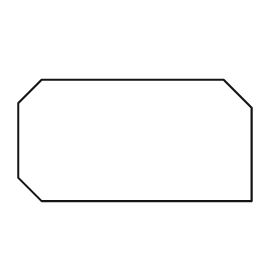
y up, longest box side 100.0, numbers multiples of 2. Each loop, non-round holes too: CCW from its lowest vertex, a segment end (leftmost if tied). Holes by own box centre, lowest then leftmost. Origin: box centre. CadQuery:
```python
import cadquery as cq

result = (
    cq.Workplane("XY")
    .moveTo(-40.0, -26.0)
    .lineTo(50.0, -26.0)
    .lineTo(50.0, 14.0)
    .lineTo(38.0, 26.0)
    .lineTo(-40.0, 26.0)
    .lineTo(-50.0, 16.0)
    .lineTo(-50.0, -16.0)
    .close()
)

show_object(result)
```